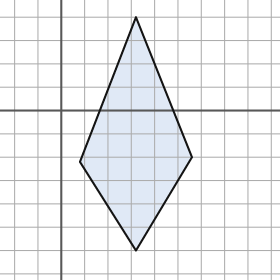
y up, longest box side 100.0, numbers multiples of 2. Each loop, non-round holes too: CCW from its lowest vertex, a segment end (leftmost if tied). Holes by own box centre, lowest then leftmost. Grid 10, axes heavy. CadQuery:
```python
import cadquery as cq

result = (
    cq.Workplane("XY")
    .moveTo(32.0, -60.0)
    .lineTo(56.0, -20.0)
    .lineTo(32.0, 40.0)
    .lineTo(8.0, -22.0)
    .close()
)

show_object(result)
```